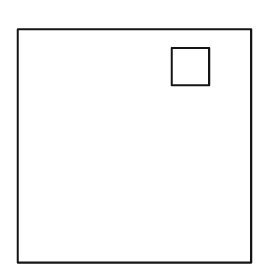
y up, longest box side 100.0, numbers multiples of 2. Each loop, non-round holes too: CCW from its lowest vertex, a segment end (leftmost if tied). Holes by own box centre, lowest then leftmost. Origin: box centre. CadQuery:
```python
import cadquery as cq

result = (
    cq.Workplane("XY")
    .moveTo(-50.0, -50.0)
    .lineTo(50.0, -50.0)
    .lineTo(50.0, 50.0)
    .lineTo(-50.0, 50.0)
    .close()
    .moveTo(16.0, 26.0)
    .lineTo(32.0, 26.0)
    .lineTo(32.0, 42.0)
    .lineTo(16.0, 42.0)
    .close()
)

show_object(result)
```